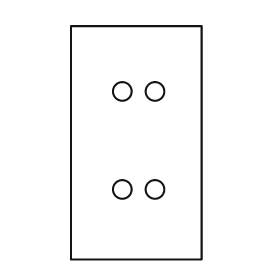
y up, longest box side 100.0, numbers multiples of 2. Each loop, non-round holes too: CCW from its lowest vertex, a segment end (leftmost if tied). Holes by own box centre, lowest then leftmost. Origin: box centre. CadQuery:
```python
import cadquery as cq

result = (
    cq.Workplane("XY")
    .moveTo(-28.0, -50.0)
    .lineTo(28.0, -50.0)
    .lineTo(28.0, 50.0)
    .lineTo(-28.0, 50.0)
    .close()
    .moveTo(-6.0, -20.0)
    .circle(4.0)
    .moveTo(8.0, -20.0)
    .circle(4.0)
    .moveTo(-6.0, 22.0)
    .circle(4.0)
    .moveTo(8.0, 22.0)
    .circle(4.0)
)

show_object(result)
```